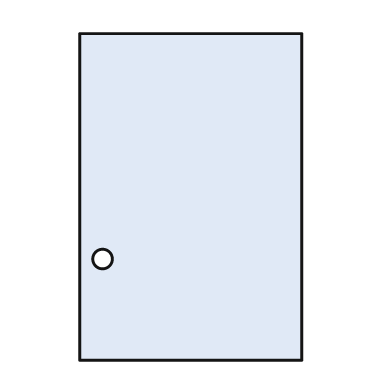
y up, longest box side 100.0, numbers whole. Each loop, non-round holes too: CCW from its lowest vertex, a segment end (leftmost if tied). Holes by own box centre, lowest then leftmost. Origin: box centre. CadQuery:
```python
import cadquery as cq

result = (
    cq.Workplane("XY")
    .moveTo(-34.0, -50.0)
    .lineTo(34.0, -50.0)
    .lineTo(34.0, 50.0)
    .lineTo(-34.0, 50.0)
    .close()
    .moveTo(-27.0, -19.0)
    .circle(3.0)
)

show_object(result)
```